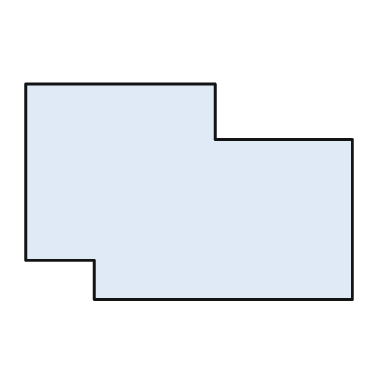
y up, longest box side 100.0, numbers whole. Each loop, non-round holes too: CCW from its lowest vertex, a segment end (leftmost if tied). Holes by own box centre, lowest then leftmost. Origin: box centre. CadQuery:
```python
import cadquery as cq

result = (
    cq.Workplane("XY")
    .moveTo(-29.0, -33.0)
    .lineTo(50.0, -33.0)
    .lineTo(50.0, 16.0)
    .lineTo(8.0, 16.0)
    .lineTo(8.0, 33.0)
    .lineTo(-50.0, 33.0)
    .lineTo(-50.0, -21.0)
    .lineTo(-29.0, -21.0)
    .close()
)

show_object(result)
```